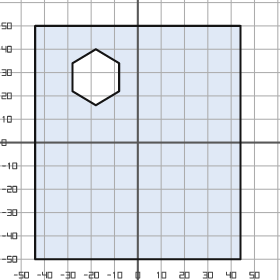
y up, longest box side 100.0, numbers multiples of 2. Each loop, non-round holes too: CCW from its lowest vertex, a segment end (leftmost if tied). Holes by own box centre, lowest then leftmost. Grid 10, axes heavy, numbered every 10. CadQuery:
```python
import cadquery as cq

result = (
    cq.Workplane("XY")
    .moveTo(-44.0, -50.0)
    .lineTo(44.0, -50.0)
    .lineTo(44.0, 50.0)
    .lineTo(-44.0, 50.0)
    .close()
    .moveTo(-18.0, 16.0)
    .lineTo(-8.0, 22.0)
    .lineTo(-8.0, 34.0)
    .lineTo(-18.0, 40.0)
    .lineTo(-28.0, 34.0)
    .lineTo(-28.0, 22.0)
    .close()
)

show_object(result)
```